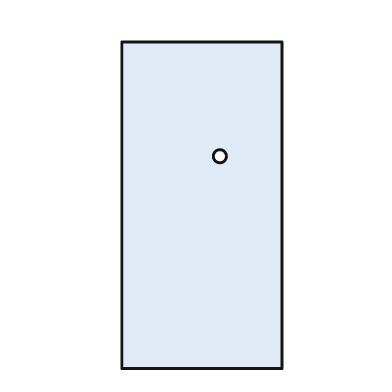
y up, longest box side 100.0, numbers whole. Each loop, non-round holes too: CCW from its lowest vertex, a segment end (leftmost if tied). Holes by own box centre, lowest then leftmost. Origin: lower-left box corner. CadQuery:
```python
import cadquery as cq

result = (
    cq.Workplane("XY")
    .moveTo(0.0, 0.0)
    .lineTo(49.0, 0.0)
    .lineTo(49.0, 100.0)
    .lineTo(0.0, 100.0)
    .close()
    .moveTo(30.0, 65.0)
    .circle(2.0)
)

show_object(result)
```